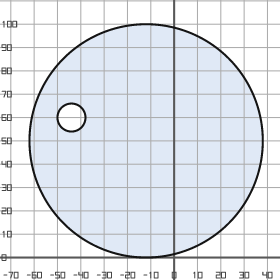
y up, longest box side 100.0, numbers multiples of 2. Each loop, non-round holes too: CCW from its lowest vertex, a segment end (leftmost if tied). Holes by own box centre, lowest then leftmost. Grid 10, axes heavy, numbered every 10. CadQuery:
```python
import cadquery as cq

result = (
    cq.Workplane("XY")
    .moveTo(-12.0, 50.0)
    .circle(50.0)
    .moveTo(-44.0, 60.0)
    .circle(6.0)
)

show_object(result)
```